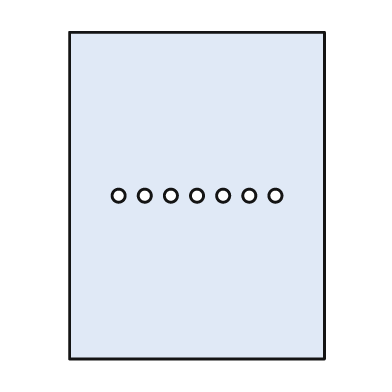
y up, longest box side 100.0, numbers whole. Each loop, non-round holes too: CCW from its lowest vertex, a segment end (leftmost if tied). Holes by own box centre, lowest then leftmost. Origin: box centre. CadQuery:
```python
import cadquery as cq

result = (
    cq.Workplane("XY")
    .moveTo(-39.0, -50.0)
    .lineTo(39.0, -50.0)
    .lineTo(39.0, 50.0)
    .lineTo(-39.0, 50.0)
    .close()
    .moveTo(-24.0, 0.0)
    .circle(2.0)
    .moveTo(-16.0, 0.0)
    .circle(2.0)
    .moveTo(-8.0, 0.0)
    .circle(2.0)
    .moveTo(0.0, 0.0)
    .circle(2.0)
    .moveTo(8.0, 0.0)
    .circle(2.0)
    .moveTo(16.0, 0.0)
    .circle(2.0)
    .moveTo(24.0, 0.0)
    .circle(2.0)
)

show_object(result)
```